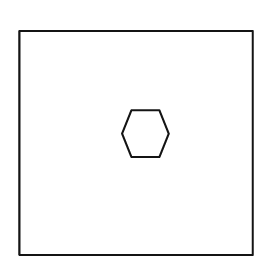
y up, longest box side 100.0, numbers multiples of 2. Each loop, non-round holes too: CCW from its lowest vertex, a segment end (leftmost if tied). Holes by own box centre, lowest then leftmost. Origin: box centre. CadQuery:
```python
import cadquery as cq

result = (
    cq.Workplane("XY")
    .moveTo(-50.0, -48.0)
    .lineTo(50.0, -48.0)
    .lineTo(50.0, 48.0)
    .lineTo(-50.0, 48.0)
    .close()
    .moveTo(-2.0, -6.0)
    .lineTo(10.0, -6.0)
    .lineTo(14.0, 4.0)
    .lineTo(10.0, 14.0)
    .lineTo(-2.0, 14.0)
    .lineTo(-6.0, 4.0)
    .close()
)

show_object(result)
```